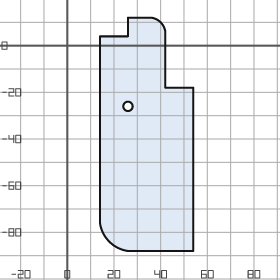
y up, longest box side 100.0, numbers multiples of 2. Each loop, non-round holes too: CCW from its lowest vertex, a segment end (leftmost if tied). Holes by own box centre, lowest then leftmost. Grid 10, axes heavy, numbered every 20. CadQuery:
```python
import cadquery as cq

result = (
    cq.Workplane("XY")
    .moveTo(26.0, -88.0)
    .lineTo(54.0, -88.0)
    .lineTo(54.0, -18.0)
    .lineTo(42.0, -18.0)
    .lineTo(42.0, 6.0)
    .threePointArc((40.0, 10.0), (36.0, 12.0))
    .lineTo(26.0, 12.0)
    .lineTo(26.0, 4.0)
    .lineTo(14.0, 4.0)
    .lineTo(14.0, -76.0)
    .threePointArc((18.0, -84.0), (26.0, -88.0))
    .close()
    .moveTo(26.0, -26.0)
    .circle(2.0)
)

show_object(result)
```